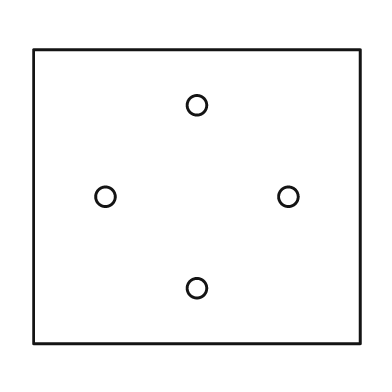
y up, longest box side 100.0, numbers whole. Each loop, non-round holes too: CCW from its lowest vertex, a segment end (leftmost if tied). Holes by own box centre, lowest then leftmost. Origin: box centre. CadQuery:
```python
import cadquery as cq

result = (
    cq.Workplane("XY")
    .moveTo(-50.0, -45.0)
    .lineTo(50.0, -45.0)
    .lineTo(50.0, 45.0)
    .lineTo(-50.0, 45.0)
    .close()
    .moveTo(0.0, -28.0)
    .circle(3.0)
    .moveTo(-28.0, 0.0)
    .circle(3.0)
    .moveTo(28.0, 0.0)
    .circle(3.0)
    .moveTo(0.0, 28.0)
    .circle(3.0)
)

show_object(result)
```